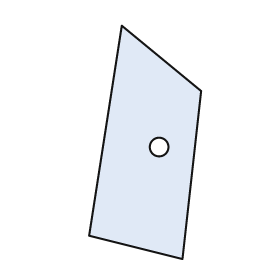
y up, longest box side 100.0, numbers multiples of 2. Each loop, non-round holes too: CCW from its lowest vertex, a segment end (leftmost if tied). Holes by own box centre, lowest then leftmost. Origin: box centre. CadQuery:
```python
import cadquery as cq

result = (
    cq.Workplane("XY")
    .moveTo(16.0, -50.0)
    .lineTo(24.0, 22.0)
    .lineTo(-10.0, 50.0)
    .lineTo(-24.0, -40.0)
    .close()
    .moveTo(6.0, -2.0)
    .circle(4.0)
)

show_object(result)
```